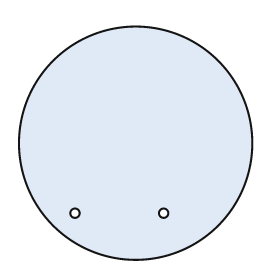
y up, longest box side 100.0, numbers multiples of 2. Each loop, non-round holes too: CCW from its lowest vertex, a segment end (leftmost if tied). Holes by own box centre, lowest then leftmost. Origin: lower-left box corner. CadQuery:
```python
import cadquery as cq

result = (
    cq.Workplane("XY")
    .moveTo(50.0, 50.0)
    .circle(50.0)
    .moveTo(24.0, 20.0)
    .circle(2.0)
    .moveTo(62.0, 20.0)
    .circle(2.0)
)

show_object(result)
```